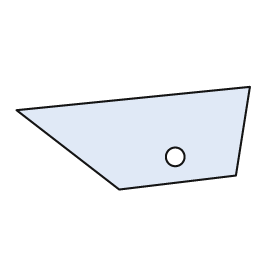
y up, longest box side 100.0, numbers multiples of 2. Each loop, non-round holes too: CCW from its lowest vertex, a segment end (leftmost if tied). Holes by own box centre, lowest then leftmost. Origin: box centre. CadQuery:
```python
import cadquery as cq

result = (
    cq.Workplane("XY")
    .moveTo(-6.0, -22.0)
    .lineTo(44.0, -16.0)
    .lineTo(50.0, 22.0)
    .lineTo(-50.0, 12.0)
    .close()
    .moveTo(18.0, -8.0)
    .circle(4.0)
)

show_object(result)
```